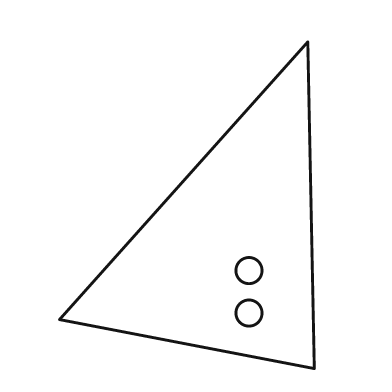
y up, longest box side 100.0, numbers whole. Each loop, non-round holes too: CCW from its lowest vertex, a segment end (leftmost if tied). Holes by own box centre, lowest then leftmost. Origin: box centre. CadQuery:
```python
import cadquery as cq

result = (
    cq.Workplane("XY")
    .moveTo(39.0, -50.0)
    .lineTo(37.0, 50.0)
    .lineTo(-39.0, -35.0)
    .close()
    .moveTo(19.0, -33.0)
    .circle(4.0)
    .moveTo(19.0, -20.0)
    .circle(4.0)
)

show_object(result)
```